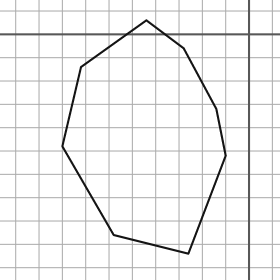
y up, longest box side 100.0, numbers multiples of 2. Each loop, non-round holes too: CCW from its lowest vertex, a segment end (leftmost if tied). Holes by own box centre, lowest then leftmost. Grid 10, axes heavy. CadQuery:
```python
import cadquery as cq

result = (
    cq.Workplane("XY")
    .moveTo(-26.0, -94.0)
    .lineTo(-10.0, -52.0)
    .lineTo(-14.0, -32.0)
    .lineTo(-28.0, -6.0)
    .lineTo(-44.0, 6.0)
    .lineTo(-72.0, -14.0)
    .lineTo(-80.0, -48.0)
    .lineTo(-58.0, -86.0)
    .close()
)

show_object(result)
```